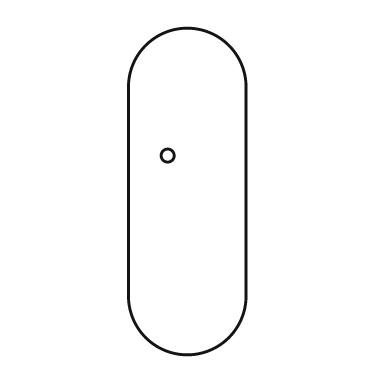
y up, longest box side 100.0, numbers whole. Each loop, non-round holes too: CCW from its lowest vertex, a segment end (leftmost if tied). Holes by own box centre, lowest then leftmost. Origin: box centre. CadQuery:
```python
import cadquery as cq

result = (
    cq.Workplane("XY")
    .moveTo(-18.0, -32.0)
    .threePointArc((0.0, -50.0), (18.0, -32.0))
    .lineTo(18.0, 32.0)
    .threePointArc((0.0, 50.0), (-18.0, 32.0))
    .close()
    .moveTo(-6.0, 11.0)
    .circle(2.0)
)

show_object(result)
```